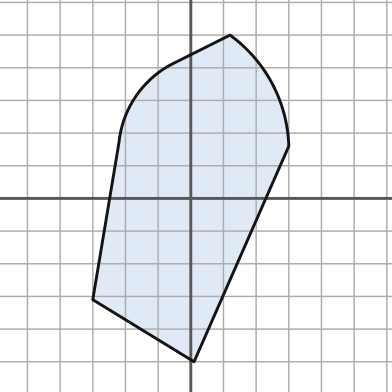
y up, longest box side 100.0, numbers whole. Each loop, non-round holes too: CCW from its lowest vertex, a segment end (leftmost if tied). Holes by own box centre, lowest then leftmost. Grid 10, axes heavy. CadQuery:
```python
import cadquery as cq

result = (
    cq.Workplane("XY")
    .moveTo(1.0, -50.0)
    .lineTo(30.0, 16.0)
    .threePointArc((25.0, 35.0), (12.0, 50.0))
    .lineTo(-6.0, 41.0)
    .threePointArc((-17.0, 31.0), (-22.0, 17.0))
    .lineTo(-30.0, -31.0)
    .close()
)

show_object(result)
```